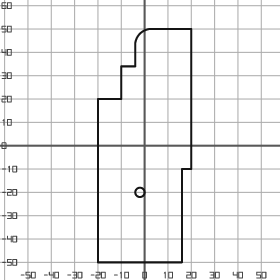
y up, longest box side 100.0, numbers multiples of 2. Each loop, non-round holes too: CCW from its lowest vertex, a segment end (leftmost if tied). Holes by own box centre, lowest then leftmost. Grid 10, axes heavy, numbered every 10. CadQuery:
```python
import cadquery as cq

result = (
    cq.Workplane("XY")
    .moveTo(-20.0, -50.0)
    .lineTo(16.0, -50.0)
    .lineTo(16.0, -10.0)
    .lineTo(20.0, -10.0)
    .lineTo(20.0, 50.0)
    .lineTo(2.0, 50.0)
    .threePointArc((-2.0, 48.0), (-4.0, 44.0))
    .lineTo(-4.0, 34.0)
    .lineTo(-10.0, 34.0)
    .lineTo(-10.0, 20.0)
    .lineTo(-20.0, 20.0)
    .close()
    .moveTo(-2.0, -20.0)
    .circle(2.0)
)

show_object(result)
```